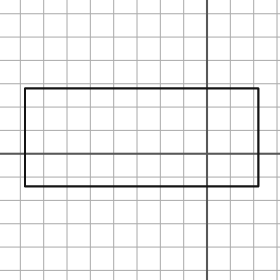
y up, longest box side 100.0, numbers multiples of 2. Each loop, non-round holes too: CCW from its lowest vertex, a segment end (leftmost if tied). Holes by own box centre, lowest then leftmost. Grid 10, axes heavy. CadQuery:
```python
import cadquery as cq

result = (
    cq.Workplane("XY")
    .moveTo(-78.0, -14.0)
    .lineTo(22.0, -14.0)
    .lineTo(22.0, 28.0)
    .lineTo(-78.0, 28.0)
    .close()
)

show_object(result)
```